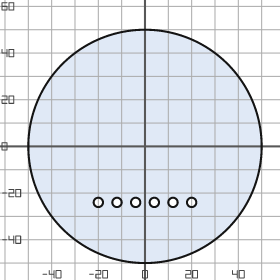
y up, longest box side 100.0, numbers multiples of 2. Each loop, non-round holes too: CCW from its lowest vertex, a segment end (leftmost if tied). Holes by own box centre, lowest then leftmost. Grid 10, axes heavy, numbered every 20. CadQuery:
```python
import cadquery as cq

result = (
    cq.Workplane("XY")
    .moveTo(0.0, 0.0)
    .circle(50.0)
    .moveTo(-20.0, -24.0)
    .circle(2.0)
    .moveTo(-12.0, -24.0)
    .circle(2.0)
    .moveTo(-4.0, -24.0)
    .circle(2.0)
    .moveTo(4.0, -24.0)
    .circle(2.0)
    .moveTo(12.0, -24.0)
    .circle(2.0)
    .moveTo(20.0, -24.0)
    .circle(2.0)
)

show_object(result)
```